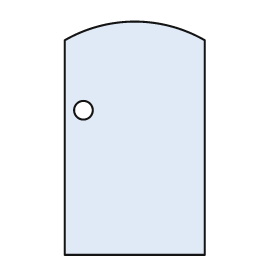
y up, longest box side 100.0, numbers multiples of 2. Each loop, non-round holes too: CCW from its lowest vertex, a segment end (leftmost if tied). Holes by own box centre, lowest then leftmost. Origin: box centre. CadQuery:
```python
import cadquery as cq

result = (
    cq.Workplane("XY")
    .moveTo(-30.0, -50.0)
    .lineTo(30.0, -50.0)
    .lineTo(30.0, 42.0)
    .threePointArc((0.0, 50.0), (-30.0, 42.0))
    .close()
    .moveTo(-22.0, 12.0)
    .circle(4.0)
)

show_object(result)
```